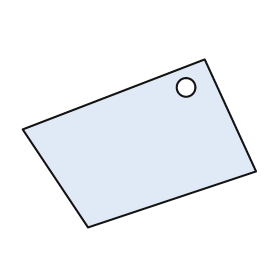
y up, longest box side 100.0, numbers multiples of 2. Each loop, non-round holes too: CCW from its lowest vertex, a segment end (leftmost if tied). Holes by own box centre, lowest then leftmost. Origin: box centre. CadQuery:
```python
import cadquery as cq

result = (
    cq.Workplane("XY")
    .moveTo(-22.0, -36.0)
    .lineTo(50.0, -12.0)
    .lineTo(28.0, 36.0)
    .lineTo(-50.0, 6.0)
    .close()
    .moveTo(20.0, 24.0)
    .circle(4.0)
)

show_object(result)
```